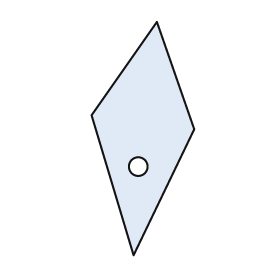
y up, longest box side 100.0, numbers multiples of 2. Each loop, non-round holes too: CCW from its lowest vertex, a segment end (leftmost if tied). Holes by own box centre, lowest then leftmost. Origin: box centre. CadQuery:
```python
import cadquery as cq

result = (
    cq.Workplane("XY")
    .moveTo(-4.0, -50.0)
    .lineTo(22.0, 4.0)
    .lineTo(6.0, 50.0)
    .lineTo(-22.0, 10.0)
    .close()
    .moveTo(-2.0, -12.0)
    .circle(4.0)
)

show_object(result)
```